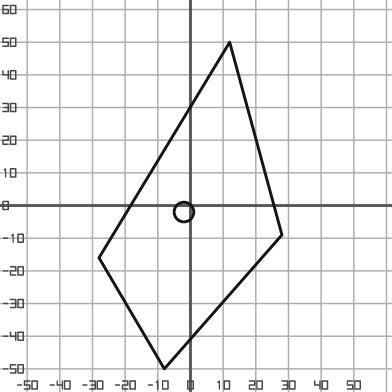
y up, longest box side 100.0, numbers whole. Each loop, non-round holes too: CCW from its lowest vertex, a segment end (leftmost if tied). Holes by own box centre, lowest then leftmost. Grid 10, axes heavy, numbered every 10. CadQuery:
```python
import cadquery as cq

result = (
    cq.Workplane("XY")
    .moveTo(-8.0, -50.0)
    .lineTo(28.0, -9.0)
    .lineTo(12.0, 50.0)
    .lineTo(-28.0, -16.0)
    .close()
    .moveTo(-2.0, -2.0)
    .circle(3.0)
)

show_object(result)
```